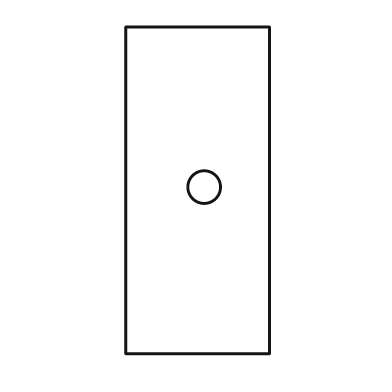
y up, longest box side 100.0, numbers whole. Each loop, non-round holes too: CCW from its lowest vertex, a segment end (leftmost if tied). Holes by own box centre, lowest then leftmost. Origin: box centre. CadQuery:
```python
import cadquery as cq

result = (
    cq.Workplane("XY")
    .moveTo(-22.0, -50.0)
    .lineTo(22.0, -50.0)
    .lineTo(22.0, 50.0)
    .lineTo(-22.0, 50.0)
    .close()
    .moveTo(2.0, 1.0)
    .circle(5.0)
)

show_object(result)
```